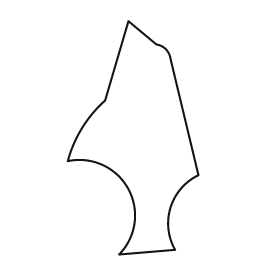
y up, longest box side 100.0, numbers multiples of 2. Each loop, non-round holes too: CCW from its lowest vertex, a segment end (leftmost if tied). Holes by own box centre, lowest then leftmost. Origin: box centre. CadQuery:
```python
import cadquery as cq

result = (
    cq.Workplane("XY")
    .moveTo(-6.0, -50.0)
    .lineTo(18.0, -48.0)
    .threePointArc((16.0, -30.0), (28.0, -16.0))
    .lineTo(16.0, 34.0)
    .threePointArc((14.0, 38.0), (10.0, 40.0))
    .lineTo(-2.0, 50.0)
    .lineTo(-12.0, 16.0)
    .threePointArc((-22.0, 4.0), (-28.0, -10.0))
    .threePointArc((-2.0, -22.0), (-6.0, -50.0))
    .close()
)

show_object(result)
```